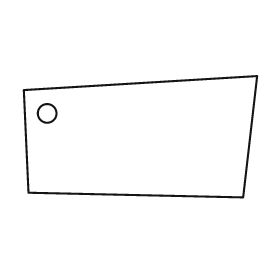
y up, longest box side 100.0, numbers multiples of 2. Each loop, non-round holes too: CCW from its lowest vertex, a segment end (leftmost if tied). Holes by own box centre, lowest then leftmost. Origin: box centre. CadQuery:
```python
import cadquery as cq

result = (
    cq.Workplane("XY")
    .moveTo(44.0, -26.0)
    .lineTo(50.0, 26.0)
    .lineTo(-50.0, 20.0)
    .lineTo(-48.0, -24.0)
    .close()
    .moveTo(-40.0, 10.0)
    .circle(4.0)
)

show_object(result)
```